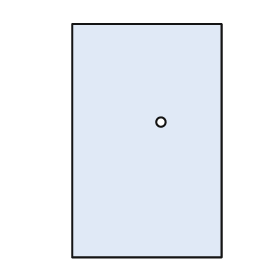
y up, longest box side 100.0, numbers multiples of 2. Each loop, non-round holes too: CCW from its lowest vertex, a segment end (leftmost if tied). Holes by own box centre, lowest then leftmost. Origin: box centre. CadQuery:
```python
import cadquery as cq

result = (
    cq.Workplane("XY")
    .moveTo(-32.0, -50.0)
    .lineTo(32.0, -50.0)
    .lineTo(32.0, 50.0)
    .lineTo(-32.0, 50.0)
    .close()
    .moveTo(6.0, 8.0)
    .circle(2.0)
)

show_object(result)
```